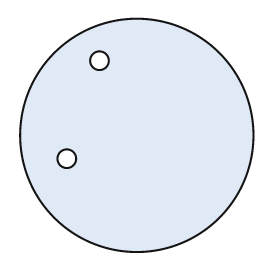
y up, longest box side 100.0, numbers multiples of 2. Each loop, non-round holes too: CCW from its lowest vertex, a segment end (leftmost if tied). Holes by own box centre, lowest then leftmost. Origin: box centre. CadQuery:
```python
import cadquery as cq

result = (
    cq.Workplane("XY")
    .moveTo(0.0, 0.0)
    .circle(50.0)
    .moveTo(-30.0, -10.0)
    .circle(4.0)
    .moveTo(-16.0, 32.0)
    .circle(4.0)
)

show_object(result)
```